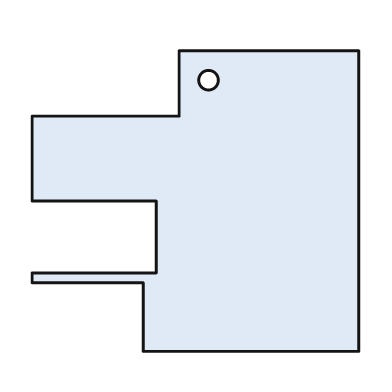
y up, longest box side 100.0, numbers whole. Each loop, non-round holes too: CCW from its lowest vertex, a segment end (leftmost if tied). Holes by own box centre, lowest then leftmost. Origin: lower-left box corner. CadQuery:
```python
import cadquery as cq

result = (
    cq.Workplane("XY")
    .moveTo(34.0, 0.0)
    .lineTo(100.0, 0.0)
    .lineTo(100.0, 92.0)
    .lineTo(45.0, 92.0)
    .lineTo(45.0, 72.0)
    .lineTo(0.0, 72.0)
    .lineTo(0.0, 46.0)
    .lineTo(38.0, 46.0)
    .lineTo(38.0, 24.0)
    .lineTo(0.0, 24.0)
    .lineTo(0.0, 21.0)
    .lineTo(34.0, 21.0)
    .close()
    .moveTo(54.0, 83.0)
    .circle(3.0)
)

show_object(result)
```